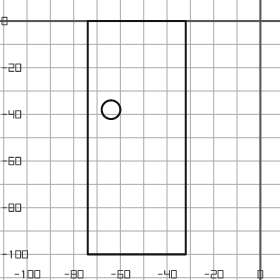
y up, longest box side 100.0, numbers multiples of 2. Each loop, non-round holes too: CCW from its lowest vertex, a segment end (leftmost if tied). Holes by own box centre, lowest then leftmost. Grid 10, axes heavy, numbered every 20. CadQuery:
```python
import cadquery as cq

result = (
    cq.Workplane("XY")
    .moveTo(-74.0, -100.0)
    .lineTo(-32.0, -100.0)
    .lineTo(-32.0, 0.0)
    .lineTo(-74.0, 0.0)
    .close()
    .moveTo(-64.0, -38.0)
    .circle(4.0)
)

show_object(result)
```